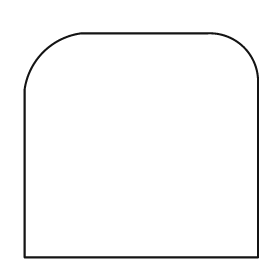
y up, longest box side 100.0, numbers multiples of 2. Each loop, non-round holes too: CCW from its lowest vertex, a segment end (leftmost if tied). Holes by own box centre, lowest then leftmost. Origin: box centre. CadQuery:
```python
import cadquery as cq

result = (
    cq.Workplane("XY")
    .moveTo(-50.0, -48.0)
    .lineTo(50.0, -48.0)
    .lineTo(50.0, 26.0)
    .threePointArc((44.0, 42.0), (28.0, 48.0))
    .lineTo(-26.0, 48.0)
    .threePointArc((-42.0, 40.0), (-50.0, 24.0))
    .close()
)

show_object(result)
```